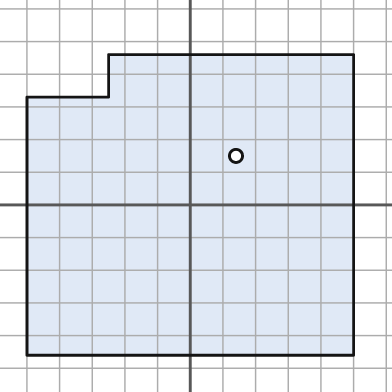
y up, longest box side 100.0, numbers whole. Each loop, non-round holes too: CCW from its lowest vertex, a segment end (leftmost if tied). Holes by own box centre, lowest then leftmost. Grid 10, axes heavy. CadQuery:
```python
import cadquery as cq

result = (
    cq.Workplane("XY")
    .moveTo(-50.0, -46.0)
    .lineTo(50.0, -46.0)
    .lineTo(50.0, 46.0)
    .lineTo(-25.0, 46.0)
    .lineTo(-25.0, 33.0)
    .lineTo(-50.0, 33.0)
    .close()
    .moveTo(14.0, 15.0)
    .circle(2.0)
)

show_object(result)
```